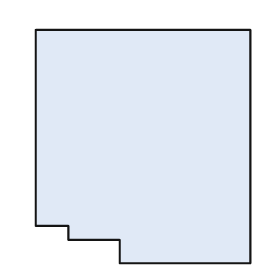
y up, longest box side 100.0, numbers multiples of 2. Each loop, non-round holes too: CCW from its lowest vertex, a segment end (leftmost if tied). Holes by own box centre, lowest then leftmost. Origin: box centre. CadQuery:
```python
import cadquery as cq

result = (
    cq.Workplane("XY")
    .moveTo(-10.0, -50.0)
    .lineTo(46.0, -50.0)
    .lineTo(46.0, 50.0)
    .lineTo(-46.0, 50.0)
    .lineTo(-46.0, -34.0)
    .lineTo(-32.0, -34.0)
    .lineTo(-32.0, -40.0)
    .lineTo(-10.0, -40.0)
    .close()
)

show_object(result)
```